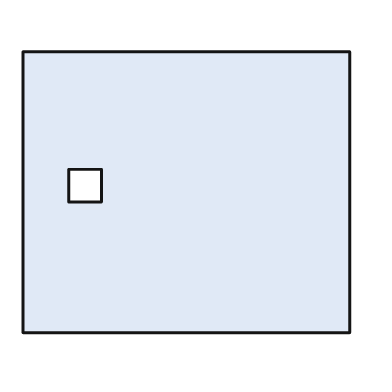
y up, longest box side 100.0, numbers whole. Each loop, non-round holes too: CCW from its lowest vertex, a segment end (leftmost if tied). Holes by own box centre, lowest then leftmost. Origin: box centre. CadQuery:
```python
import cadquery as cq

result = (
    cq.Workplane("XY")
    .moveTo(-50.0, -43.0)
    .lineTo(50.0, -43.0)
    .lineTo(50.0, 43.0)
    .lineTo(-50.0, 43.0)
    .close()
    .moveTo(-36.0, -3.0)
    .lineTo(-26.0, -3.0)
    .lineTo(-26.0, 7.0)
    .lineTo(-36.0, 7.0)
    .close()
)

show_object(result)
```